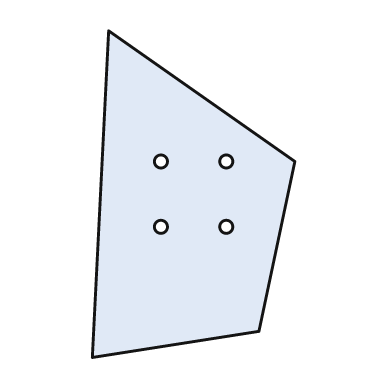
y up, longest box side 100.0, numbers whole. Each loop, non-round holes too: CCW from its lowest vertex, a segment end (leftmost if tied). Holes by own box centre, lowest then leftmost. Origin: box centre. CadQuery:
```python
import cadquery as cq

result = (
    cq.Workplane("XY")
    .moveTo(-31.0, -50.0)
    .lineTo(20.0, -42.0)
    .lineTo(31.0, 10.0)
    .lineTo(-26.0, 50.0)
    .close()
    .moveTo(-10.0, -10.0)
    .circle(2.0)
    .moveTo(10.0, -10.0)
    .circle(2.0)
    .moveTo(-10.0, 10.0)
    .circle(2.0)
    .moveTo(10.0, 10.0)
    .circle(2.0)
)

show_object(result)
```